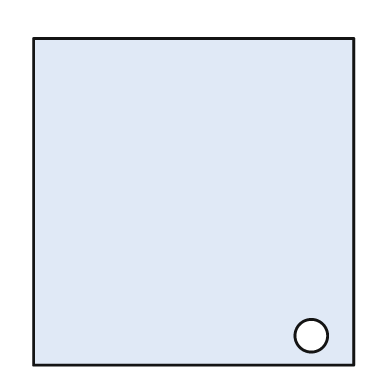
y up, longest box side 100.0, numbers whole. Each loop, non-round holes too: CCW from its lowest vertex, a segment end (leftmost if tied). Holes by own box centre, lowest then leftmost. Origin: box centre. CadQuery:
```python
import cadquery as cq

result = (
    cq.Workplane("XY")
    .moveTo(-49.0, -50.0)
    .lineTo(49.0, -50.0)
    .lineTo(49.0, 50.0)
    .lineTo(-49.0, 50.0)
    .close()
    .moveTo(36.0, -41.0)
    .circle(5.0)
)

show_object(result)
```